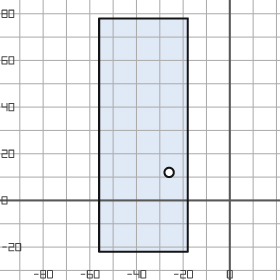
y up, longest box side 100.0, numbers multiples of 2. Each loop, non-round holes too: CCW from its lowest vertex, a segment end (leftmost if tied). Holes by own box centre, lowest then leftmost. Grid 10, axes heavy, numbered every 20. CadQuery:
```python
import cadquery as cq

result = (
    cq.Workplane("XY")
    .moveTo(-56.0, -22.0)
    .lineTo(-18.0, -22.0)
    .lineTo(-18.0, 78.0)
    .lineTo(-56.0, 78.0)
    .close()
    .moveTo(-26.0, 12.0)
    .circle(2.0)
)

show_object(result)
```